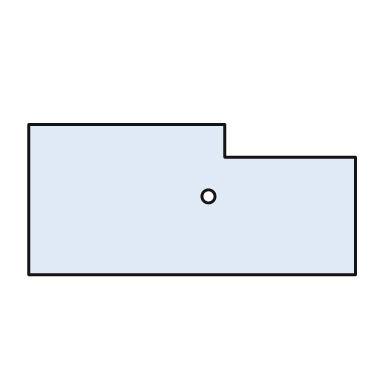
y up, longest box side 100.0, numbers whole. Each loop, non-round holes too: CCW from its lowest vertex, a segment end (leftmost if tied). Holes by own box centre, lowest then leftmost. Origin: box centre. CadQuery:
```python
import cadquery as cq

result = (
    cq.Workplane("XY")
    .moveTo(-50.0, -23.0)
    .lineTo(50.0, -23.0)
    .lineTo(50.0, 13.0)
    .lineTo(10.0, 13.0)
    .lineTo(10.0, 23.0)
    .lineTo(-50.0, 23.0)
    .close()
    .moveTo(5.0, 1.0)
    .circle(2.0)
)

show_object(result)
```